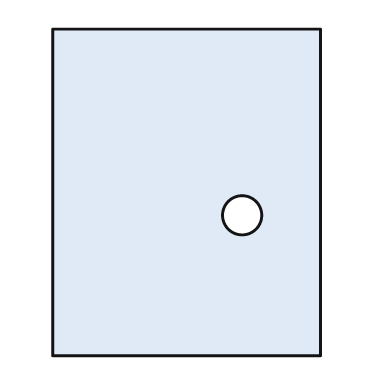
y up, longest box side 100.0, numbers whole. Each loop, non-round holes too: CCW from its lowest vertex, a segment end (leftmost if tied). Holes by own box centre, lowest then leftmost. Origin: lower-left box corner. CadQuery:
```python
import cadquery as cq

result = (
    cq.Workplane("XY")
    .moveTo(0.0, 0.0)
    .lineTo(82.0, 0.0)
    .lineTo(82.0, 100.0)
    .lineTo(0.0, 100.0)
    .close()
    .moveTo(58.0, 43.0)
    .circle(6.0)
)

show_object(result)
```